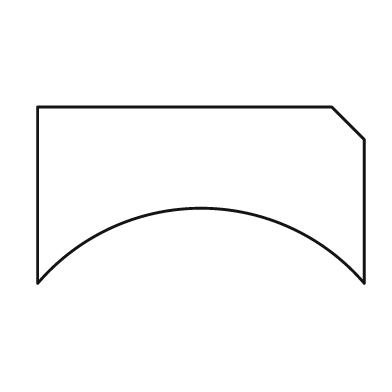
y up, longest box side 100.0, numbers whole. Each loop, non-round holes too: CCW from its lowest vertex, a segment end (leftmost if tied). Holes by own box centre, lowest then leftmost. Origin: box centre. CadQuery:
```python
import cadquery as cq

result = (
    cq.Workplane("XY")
    .moveTo(-50.0, -27.0)
    .threePointArc((0.0, -4.0), (50.0, -27.0))
    .lineTo(50.0, 17.0)
    .lineTo(40.0, 27.0)
    .lineTo(-50.0, 27.0)
    .close()
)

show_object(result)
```